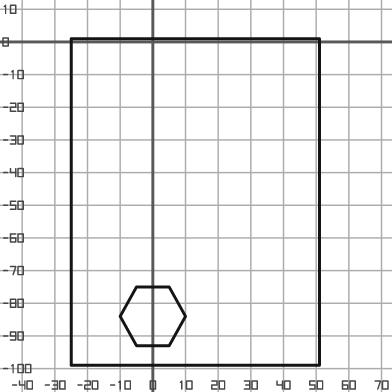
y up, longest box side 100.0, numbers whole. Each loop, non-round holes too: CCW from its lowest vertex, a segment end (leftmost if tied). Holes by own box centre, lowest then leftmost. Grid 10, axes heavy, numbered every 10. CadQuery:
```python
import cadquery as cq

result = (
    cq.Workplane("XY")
    .moveTo(-25.0, -99.0)
    .lineTo(51.0, -99.0)
    .lineTo(51.0, 1.0)
    .lineTo(-25.0, 1.0)
    .close()
    .moveTo(-5.0, -93.0)
    .lineTo(5.0, -93.0)
    .lineTo(10.0, -84.0)
    .lineTo(5.0, -75.0)
    .lineTo(-5.0, -75.0)
    .lineTo(-10.0, -84.0)
    .close()
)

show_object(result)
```